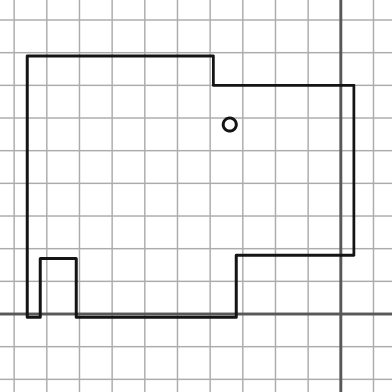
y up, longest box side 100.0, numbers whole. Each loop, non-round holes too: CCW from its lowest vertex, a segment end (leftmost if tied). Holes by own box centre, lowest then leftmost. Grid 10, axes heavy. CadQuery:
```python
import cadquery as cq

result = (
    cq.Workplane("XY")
    .moveTo(-96.0, -1.0)
    .lineTo(-92.0, -1.0)
    .lineTo(-92.0, 17.0)
    .lineTo(-81.0, 17.0)
    .lineTo(-81.0, -1.0)
    .lineTo(-32.0, -1.0)
    .lineTo(-32.0, 18.0)
    .lineTo(4.0, 18.0)
    .lineTo(4.0, 70.0)
    .lineTo(-39.0, 70.0)
    .lineTo(-39.0, 79.0)
    .lineTo(-96.0, 79.0)
    .close()
    .moveTo(-34.0, 58.0)
    .circle(2.0)
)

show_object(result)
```